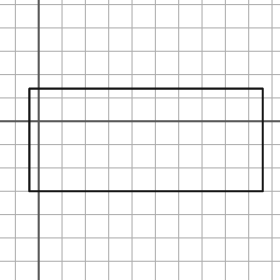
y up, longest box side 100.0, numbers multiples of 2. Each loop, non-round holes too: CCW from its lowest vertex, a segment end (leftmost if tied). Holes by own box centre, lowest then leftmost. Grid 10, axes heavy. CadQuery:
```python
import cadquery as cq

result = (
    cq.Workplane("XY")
    .moveTo(-4.0, -30.0)
    .lineTo(96.0, -30.0)
    .lineTo(96.0, 14.0)
    .lineTo(-4.0, 14.0)
    .close()
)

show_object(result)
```